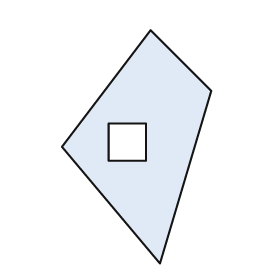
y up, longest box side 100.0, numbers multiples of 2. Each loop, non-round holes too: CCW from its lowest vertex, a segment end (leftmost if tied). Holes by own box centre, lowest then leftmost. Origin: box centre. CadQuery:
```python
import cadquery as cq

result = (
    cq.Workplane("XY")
    .moveTo(10.0, -50.0)
    .lineTo(32.0, 24.0)
    .lineTo(6.0, 50.0)
    .lineTo(-32.0, 0.0)
    .close()
    .moveTo(-12.0, -6.0)
    .lineTo(4.0, -6.0)
    .lineTo(4.0, 10.0)
    .lineTo(-12.0, 10.0)
    .close()
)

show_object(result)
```